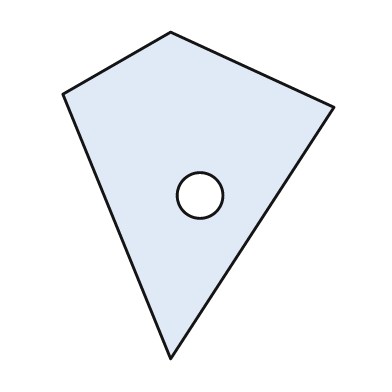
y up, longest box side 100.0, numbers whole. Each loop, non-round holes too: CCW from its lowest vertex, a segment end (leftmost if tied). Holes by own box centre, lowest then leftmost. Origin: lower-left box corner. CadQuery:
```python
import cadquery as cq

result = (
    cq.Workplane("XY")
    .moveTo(33.0, 0.0)
    .lineTo(83.0, 77.0)
    .lineTo(33.0, 100.0)
    .lineTo(0.0, 81.0)
    .close()
    .moveTo(42.0, 50.0)
    .circle(7.0)
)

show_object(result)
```